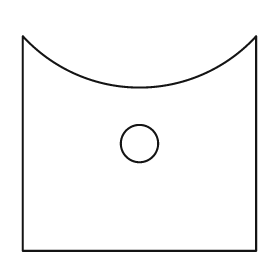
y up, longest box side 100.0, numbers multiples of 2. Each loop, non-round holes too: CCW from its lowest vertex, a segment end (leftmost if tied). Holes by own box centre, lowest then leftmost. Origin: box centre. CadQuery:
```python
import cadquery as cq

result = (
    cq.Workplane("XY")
    .moveTo(-50.0, -46.0)
    .lineTo(50.0, -46.0)
    .lineTo(50.0, 46.0)
    .threePointArc((0.0, 24.0), (-50.0, 46.0))
    .close()
    .moveTo(0.0, 0.0)
    .circle(8.0)
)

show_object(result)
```